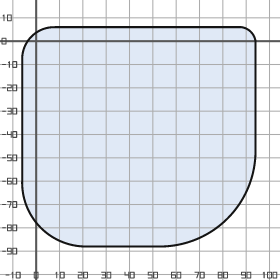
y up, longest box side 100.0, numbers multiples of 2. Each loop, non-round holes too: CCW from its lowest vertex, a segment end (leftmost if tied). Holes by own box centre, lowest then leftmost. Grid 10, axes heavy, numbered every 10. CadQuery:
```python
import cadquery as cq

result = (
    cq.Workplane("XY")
    .moveTo(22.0, -88.0)
    .lineTo(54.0, -88.0)
    .threePointArc((82.0, -76.0), (94.0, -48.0))
    .lineTo(94.0, 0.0)
    .threePointArc((92.0, 4.0), (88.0, 6.0))
    .lineTo(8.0, 6.0)
    .threePointArc((-2.0, 2.0), (-6.0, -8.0))
    .lineTo(-6.0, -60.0)
    .threePointArc((2.0, -80.0), (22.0, -88.0))
    .close()
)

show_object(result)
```